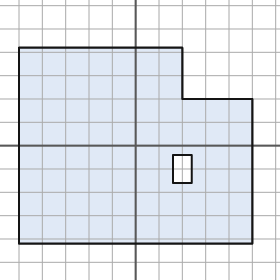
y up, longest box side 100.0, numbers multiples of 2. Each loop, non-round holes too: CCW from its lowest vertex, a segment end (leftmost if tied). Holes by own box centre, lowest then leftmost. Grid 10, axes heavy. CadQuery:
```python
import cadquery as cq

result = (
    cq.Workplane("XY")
    .moveTo(-50.0, -42.0)
    .lineTo(50.0, -42.0)
    .lineTo(50.0, 20.0)
    .lineTo(20.0, 20.0)
    .lineTo(20.0, 42.0)
    .lineTo(-50.0, 42.0)
    .close()
    .moveTo(16.0, -16.0)
    .lineTo(24.0, -16.0)
    .lineTo(24.0, -4.0)
    .lineTo(16.0, -4.0)
    .close()
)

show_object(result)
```